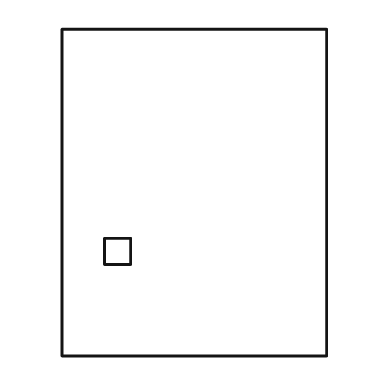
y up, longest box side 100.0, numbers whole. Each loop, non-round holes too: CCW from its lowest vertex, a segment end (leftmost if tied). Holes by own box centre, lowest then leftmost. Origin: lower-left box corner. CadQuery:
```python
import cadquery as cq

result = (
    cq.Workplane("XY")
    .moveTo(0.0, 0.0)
    .lineTo(81.0, 0.0)
    .lineTo(81.0, 100.0)
    .lineTo(0.0, 100.0)
    .close()
    .moveTo(13.0, 28.0)
    .lineTo(21.0, 28.0)
    .lineTo(21.0, 36.0)
    .lineTo(13.0, 36.0)
    .close()
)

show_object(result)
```